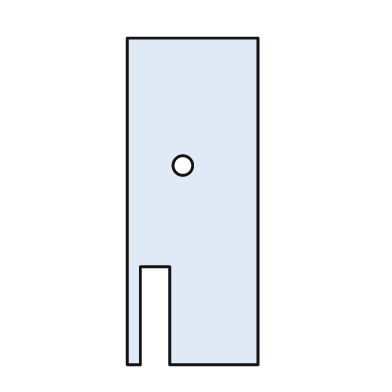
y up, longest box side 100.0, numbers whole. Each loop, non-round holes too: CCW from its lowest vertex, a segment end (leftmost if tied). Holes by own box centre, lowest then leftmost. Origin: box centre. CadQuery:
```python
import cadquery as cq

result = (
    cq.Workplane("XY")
    .moveTo(-20.0, -50.0)
    .lineTo(-16.0, -50.0)
    .lineTo(-16.0, -20.0)
    .lineTo(-7.0, -20.0)
    .lineTo(-7.0, -50.0)
    .lineTo(20.0, -50.0)
    .lineTo(20.0, 50.0)
    .lineTo(-20.0, 50.0)
    .close()
    .moveTo(-3.0, 11.0)
    .circle(3.0)
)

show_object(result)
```